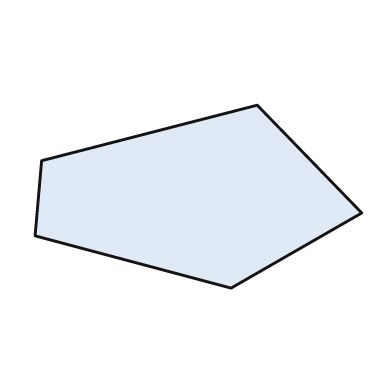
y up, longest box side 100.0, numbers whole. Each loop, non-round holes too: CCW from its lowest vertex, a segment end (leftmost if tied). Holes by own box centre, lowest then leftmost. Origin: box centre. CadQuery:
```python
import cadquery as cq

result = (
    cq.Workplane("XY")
    .moveTo(10.0, -28.0)
    .lineTo(50.0, -5.0)
    .lineTo(18.0, 28.0)
    .lineTo(-48.0, 11.0)
    .lineTo(-50.0, -12.0)
    .close()
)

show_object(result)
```